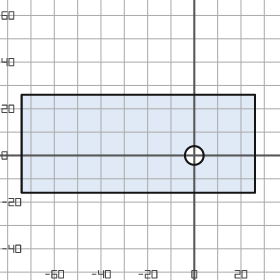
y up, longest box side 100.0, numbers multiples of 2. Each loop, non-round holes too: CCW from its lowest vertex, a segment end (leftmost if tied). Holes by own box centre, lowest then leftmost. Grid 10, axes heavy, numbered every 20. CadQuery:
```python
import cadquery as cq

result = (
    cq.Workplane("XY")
    .moveTo(-74.0, -16.0)
    .lineTo(26.0, -16.0)
    .lineTo(26.0, 26.0)
    .lineTo(-74.0, 26.0)
    .close()
    .moveTo(0.0, 0.0)
    .circle(4.0)
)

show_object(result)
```